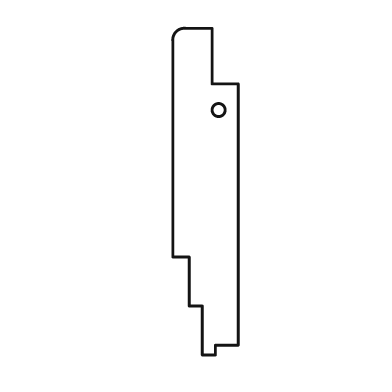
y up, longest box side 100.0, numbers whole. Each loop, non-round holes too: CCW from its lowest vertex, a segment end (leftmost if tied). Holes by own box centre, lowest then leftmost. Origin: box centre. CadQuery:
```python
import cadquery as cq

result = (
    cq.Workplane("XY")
    .moveTo(-1.0, -50.0)
    .lineTo(3.0, -50.0)
    .lineTo(3.0, -47.0)
    .lineTo(10.0, -47.0)
    .lineTo(10.0, 33.0)
    .lineTo(2.0, 33.0)
    .lineTo(2.0, 50.0)
    .lineTo(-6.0, 50.0)
    .threePointArc((-9.0, 49.0), (-10.0, 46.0))
    .lineTo(-10.0, -20.0)
    .lineTo(-5.0, -20.0)
    .lineTo(-5.0, -35.0)
    .lineTo(-1.0, -35.0)
    .close()
    .moveTo(4.0, 25.0)
    .circle(2.0)
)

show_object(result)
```